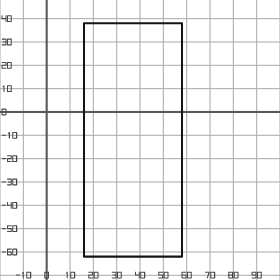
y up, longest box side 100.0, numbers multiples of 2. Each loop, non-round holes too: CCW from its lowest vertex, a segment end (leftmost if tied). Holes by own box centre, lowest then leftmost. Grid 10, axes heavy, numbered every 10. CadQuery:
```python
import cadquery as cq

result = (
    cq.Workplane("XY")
    .moveTo(16.0, -62.0)
    .lineTo(58.0, -62.0)
    .lineTo(58.0, 38.0)
    .lineTo(16.0, 38.0)
    .close()
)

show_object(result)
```